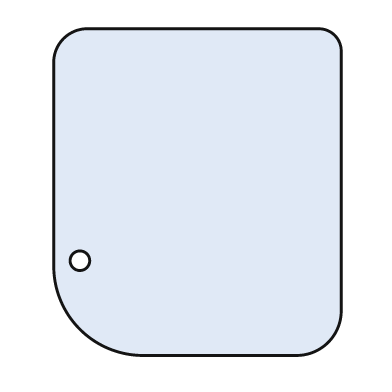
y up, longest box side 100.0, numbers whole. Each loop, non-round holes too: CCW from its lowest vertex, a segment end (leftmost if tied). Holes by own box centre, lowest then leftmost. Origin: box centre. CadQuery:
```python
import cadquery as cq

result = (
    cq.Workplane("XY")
    .moveTo(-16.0, -50.0)
    .lineTo(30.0, -50.0)
    .threePointArc((40.0, -46.0), (44.0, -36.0))
    .lineTo(44.0, 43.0)
    .threePointArc((42.0, 48.0), (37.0, 50.0))
    .lineTo(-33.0, 50.0)
    .threePointArc((-41.0, 47.0), (-44.0, 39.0))
    .lineTo(-44.0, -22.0)
    .threePointArc((-36.0, -42.0), (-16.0, -50.0))
    .close()
    .moveTo(-36.0, -21.0)
    .circle(3.0)
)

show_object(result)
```